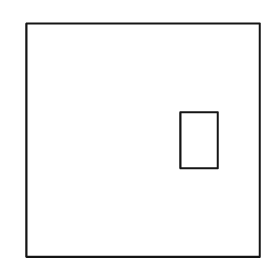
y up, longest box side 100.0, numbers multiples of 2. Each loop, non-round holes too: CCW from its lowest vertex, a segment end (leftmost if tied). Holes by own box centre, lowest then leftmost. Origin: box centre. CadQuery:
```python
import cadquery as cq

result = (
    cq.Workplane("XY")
    .moveTo(-50.0, -50.0)
    .lineTo(50.0, -50.0)
    .lineTo(50.0, 50.0)
    .lineTo(-50.0, 50.0)
    .close()
    .moveTo(16.0, -12.0)
    .lineTo(32.0, -12.0)
    .lineTo(32.0, 12.0)
    .lineTo(16.0, 12.0)
    .close()
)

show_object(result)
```